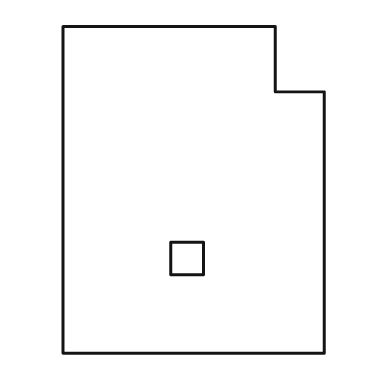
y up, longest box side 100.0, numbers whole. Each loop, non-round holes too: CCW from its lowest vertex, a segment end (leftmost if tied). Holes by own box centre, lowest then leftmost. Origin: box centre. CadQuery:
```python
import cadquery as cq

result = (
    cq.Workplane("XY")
    .moveTo(-40.0, -50.0)
    .lineTo(40.0, -50.0)
    .lineTo(40.0, 30.0)
    .lineTo(25.0, 30.0)
    .lineTo(25.0, 50.0)
    .lineTo(-40.0, 50.0)
    .close()
    .moveTo(-7.0, -26.0)
    .lineTo(3.0, -26.0)
    .lineTo(3.0, -16.0)
    .lineTo(-7.0, -16.0)
    .close()
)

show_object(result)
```